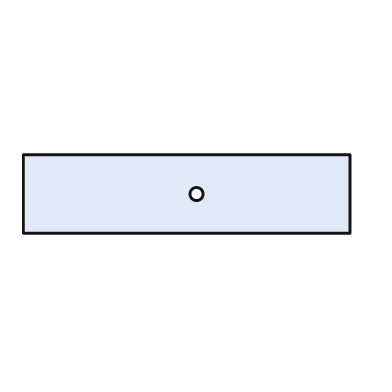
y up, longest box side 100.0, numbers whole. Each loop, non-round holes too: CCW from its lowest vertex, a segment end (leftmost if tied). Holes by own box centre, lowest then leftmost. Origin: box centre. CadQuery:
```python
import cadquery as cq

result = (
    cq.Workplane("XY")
    .moveTo(-50.0, -12.0)
    .lineTo(50.0, -12.0)
    .lineTo(50.0, 12.0)
    .lineTo(-50.0, 12.0)
    .close()
    .moveTo(3.0, 0.0)
    .circle(2.0)
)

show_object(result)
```